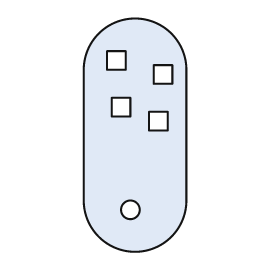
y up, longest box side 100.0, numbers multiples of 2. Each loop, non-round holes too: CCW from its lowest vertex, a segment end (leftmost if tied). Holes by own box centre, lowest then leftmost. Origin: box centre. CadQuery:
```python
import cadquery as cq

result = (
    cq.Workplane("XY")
    .moveTo(-22.0, -28.0)
    .threePointArc((0.0, -50.0), (22.0, -28.0))
    .lineTo(22.0, 28.0)
    .threePointArc((0.0, 50.0), (-22.0, 28.0))
    .close()
    .moveTo(-2.0, -32.0)
    .circle(4.0)
    .moveTo(6.0, 2.0)
    .lineTo(14.0, 2.0)
    .lineTo(14.0, 10.0)
    .lineTo(6.0, 10.0)
    .close()
    .moveTo(-10.0, 8.0)
    .lineTo(-2.0, 8.0)
    .lineTo(-2.0, 16.0)
    .lineTo(-10.0, 16.0)
    .close()
    .moveTo(8.0, 22.0)
    .lineTo(16.0, 22.0)
    .lineTo(16.0, 30.0)
    .lineTo(8.0, 30.0)
    .close()
    .moveTo(-12.0, 28.0)
    .lineTo(-4.0, 28.0)
    .lineTo(-4.0, 36.0)
    .lineTo(-12.0, 36.0)
    .close()
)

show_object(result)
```